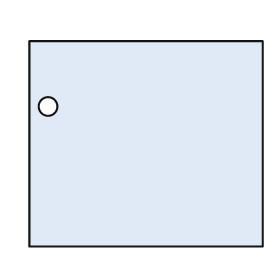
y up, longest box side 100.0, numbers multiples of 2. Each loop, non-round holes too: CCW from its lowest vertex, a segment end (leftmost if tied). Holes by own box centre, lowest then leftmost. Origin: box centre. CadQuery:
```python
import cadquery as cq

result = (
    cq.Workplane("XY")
    .moveTo(-50.0, -44.0)
    .lineTo(50.0, -44.0)
    .lineTo(50.0, 44.0)
    .lineTo(-50.0, 44.0)
    .close()
    .moveTo(-42.0, 16.0)
    .circle(4.0)
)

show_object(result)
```